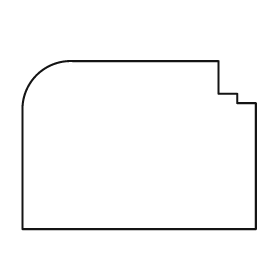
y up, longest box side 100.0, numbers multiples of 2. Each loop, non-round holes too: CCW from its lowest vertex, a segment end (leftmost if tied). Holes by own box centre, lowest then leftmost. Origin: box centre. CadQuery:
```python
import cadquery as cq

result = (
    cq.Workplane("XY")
    .moveTo(-50.0, -36.0)
    .lineTo(50.0, -36.0)
    .lineTo(50.0, 18.0)
    .lineTo(42.0, 18.0)
    .lineTo(42.0, 22.0)
    .lineTo(34.0, 22.0)
    .lineTo(34.0, 36.0)
    .lineTo(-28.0, 36.0)
    .threePointArc((-44.0, 30.0), (-50.0, 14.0))
    .close()
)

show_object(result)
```